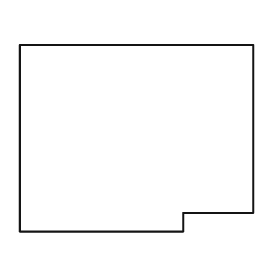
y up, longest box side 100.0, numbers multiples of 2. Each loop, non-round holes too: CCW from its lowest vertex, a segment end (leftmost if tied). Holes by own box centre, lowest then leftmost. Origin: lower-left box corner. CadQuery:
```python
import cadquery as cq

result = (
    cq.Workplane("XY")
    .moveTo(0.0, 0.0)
    .lineTo(70.0, 0.0)
    .lineTo(70.0, 8.0)
    .lineTo(100.0, 8.0)
    .lineTo(100.0, 80.0)
    .lineTo(0.0, 80.0)
    .close()
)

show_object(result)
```